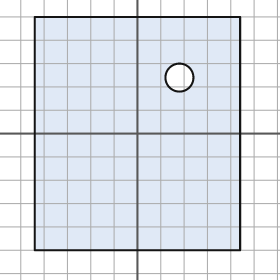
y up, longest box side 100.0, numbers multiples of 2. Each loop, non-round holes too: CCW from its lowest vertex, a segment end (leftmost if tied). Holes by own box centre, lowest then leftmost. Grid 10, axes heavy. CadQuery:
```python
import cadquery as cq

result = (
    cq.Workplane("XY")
    .moveTo(-44.0, -50.0)
    .lineTo(44.0, -50.0)
    .lineTo(44.0, 50.0)
    .lineTo(-44.0, 50.0)
    .close()
    .moveTo(18.0, 24.0)
    .circle(6.0)
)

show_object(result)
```